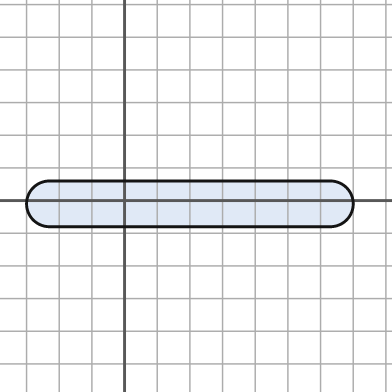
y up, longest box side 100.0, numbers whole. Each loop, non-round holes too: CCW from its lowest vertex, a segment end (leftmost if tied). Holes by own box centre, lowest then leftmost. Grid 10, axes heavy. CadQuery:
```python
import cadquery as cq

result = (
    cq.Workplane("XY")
    .moveTo(-23.0, -8.0)
    .lineTo(63.0, -8.0)
    .threePointArc((70.0, -1.0), (63.0, 6.0))
    .lineTo(-23.0, 6.0)
    .threePointArc((-30.0, -1.0), (-23.0, -8.0))
    .close()
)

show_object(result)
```